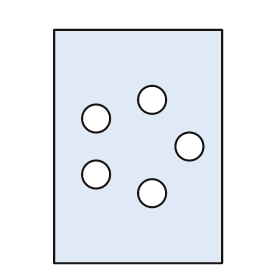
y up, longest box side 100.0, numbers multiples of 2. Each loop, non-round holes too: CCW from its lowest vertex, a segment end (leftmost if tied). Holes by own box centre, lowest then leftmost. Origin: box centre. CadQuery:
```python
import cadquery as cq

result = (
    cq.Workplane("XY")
    .moveTo(-36.0, -50.0)
    .lineTo(36.0, -50.0)
    .lineTo(36.0, 50.0)
    .lineTo(-36.0, 50.0)
    .close()
    .moveTo(6.0, -20.0)
    .circle(6.0)
    .moveTo(-18.0, -12.0)
    .circle(6.0)
    .moveTo(22.0, 0.0)
    .circle(6.0)
    .moveTo(-18.0, 12.0)
    .circle(6.0)
    .moveTo(6.0, 20.0)
    .circle(6.0)
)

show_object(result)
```